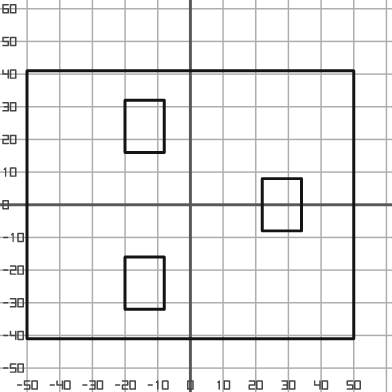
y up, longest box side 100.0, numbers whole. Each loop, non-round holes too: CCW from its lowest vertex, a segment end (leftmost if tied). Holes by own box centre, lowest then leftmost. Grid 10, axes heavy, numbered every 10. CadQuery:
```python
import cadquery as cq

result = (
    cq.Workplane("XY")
    .moveTo(-50.0, -41.0)
    .lineTo(50.0, -41.0)
    .lineTo(50.0, 41.0)
    .lineTo(-50.0, 41.0)
    .close()
    .moveTo(-20.0, -32.0)
    .lineTo(-8.0, -32.0)
    .lineTo(-8.0, -16.0)
    .lineTo(-20.0, -16.0)
    .close()
    .moveTo(22.0, -8.0)
    .lineTo(34.0, -8.0)
    .lineTo(34.0, 8.0)
    .lineTo(22.0, 8.0)
    .close()
    .moveTo(-20.0, 16.0)
    .lineTo(-8.0, 16.0)
    .lineTo(-8.0, 32.0)
    .lineTo(-20.0, 32.0)
    .close()
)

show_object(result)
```